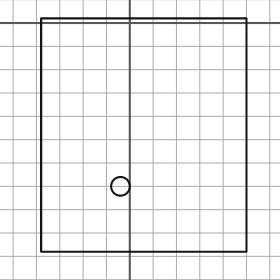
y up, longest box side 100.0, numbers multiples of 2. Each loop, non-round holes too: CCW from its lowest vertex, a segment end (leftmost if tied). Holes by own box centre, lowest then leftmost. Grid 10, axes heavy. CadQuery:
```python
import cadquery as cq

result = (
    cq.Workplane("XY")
    .moveTo(-38.0, -98.0)
    .lineTo(50.0, -98.0)
    .lineTo(50.0, 2.0)
    .lineTo(-38.0, 2.0)
    .close()
    .moveTo(-4.0, -70.0)
    .circle(4.0)
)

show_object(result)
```